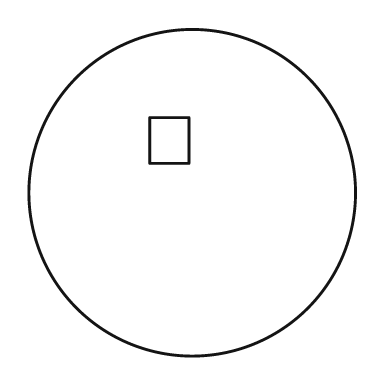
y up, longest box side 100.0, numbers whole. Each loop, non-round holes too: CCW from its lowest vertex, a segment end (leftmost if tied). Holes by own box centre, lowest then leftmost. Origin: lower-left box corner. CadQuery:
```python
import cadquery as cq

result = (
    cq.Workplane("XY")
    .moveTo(50.0, 50.0)
    .circle(50.0)
    .moveTo(37.0, 59.0)
    .lineTo(49.0, 59.0)
    .lineTo(49.0, 73.0)
    .lineTo(37.0, 73.0)
    .close()
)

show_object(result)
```